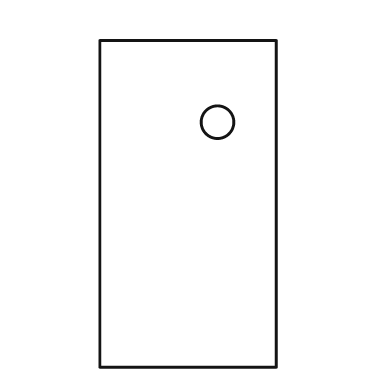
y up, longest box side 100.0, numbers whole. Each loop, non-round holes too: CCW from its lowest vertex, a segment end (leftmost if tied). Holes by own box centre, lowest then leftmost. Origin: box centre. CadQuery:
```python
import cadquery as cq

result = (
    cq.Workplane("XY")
    .moveTo(-27.0, -50.0)
    .lineTo(27.0, -50.0)
    .lineTo(27.0, 50.0)
    .lineTo(-27.0, 50.0)
    .close()
    .moveTo(9.0, 25.0)
    .circle(5.0)
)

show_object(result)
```